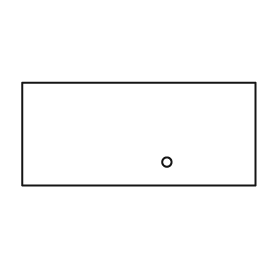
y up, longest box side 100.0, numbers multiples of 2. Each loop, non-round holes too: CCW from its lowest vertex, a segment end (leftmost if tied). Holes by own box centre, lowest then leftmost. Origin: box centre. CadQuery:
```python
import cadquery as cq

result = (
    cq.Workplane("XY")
    .moveTo(-50.0, -22.0)
    .lineTo(50.0, -22.0)
    .lineTo(50.0, 22.0)
    .lineTo(-50.0, 22.0)
    .close()
    .moveTo(12.0, -12.0)
    .circle(2.0)
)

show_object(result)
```